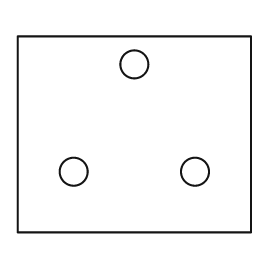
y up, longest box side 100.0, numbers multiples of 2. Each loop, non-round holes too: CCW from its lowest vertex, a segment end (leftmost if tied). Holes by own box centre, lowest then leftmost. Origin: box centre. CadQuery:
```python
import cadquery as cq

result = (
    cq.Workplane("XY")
    .moveTo(-50.0, -42.0)
    .lineTo(50.0, -42.0)
    .lineTo(50.0, 42.0)
    .lineTo(-50.0, 42.0)
    .close()
    .moveTo(-26.0, -16.0)
    .circle(6.0)
    .moveTo(26.0, -16.0)
    .circle(6.0)
    .moveTo(0.0, 30.0)
    .circle(6.0)
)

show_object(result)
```